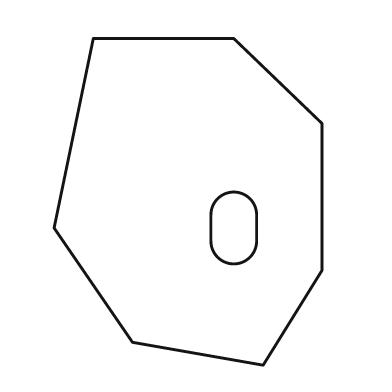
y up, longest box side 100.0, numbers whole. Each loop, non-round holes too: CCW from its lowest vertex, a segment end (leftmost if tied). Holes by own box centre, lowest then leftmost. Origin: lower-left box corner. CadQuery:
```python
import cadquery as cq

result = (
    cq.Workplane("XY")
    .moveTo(64.0, 0.0)
    .lineTo(82.0, 29.0)
    .lineTo(82.0, 74.0)
    .lineTo(55.0, 100.0)
    .lineTo(12.0, 100.0)
    .lineTo(0.0, 42.0)
    .lineTo(24.0, 7.0)
    .close()
    .moveTo(48.0, 38.0)
    .threePointArc((55.0, 31.0), (62.0, 38.0))
    .lineTo(62.0, 46.0)
    .threePointArc((55.0, 53.0), (48.0, 46.0))
    .close()
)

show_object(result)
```